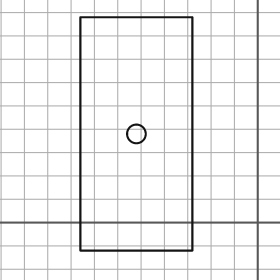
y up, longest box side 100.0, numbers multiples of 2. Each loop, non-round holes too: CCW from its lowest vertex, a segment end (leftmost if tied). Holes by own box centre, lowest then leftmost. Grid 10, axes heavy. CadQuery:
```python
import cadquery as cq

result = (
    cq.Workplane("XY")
    .moveTo(-76.0, -12.0)
    .lineTo(-28.0, -12.0)
    .lineTo(-28.0, 88.0)
    .lineTo(-76.0, 88.0)
    .close()
    .moveTo(-52.0, 38.0)
    .circle(4.0)
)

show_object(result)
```